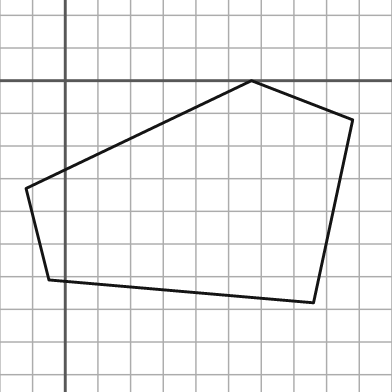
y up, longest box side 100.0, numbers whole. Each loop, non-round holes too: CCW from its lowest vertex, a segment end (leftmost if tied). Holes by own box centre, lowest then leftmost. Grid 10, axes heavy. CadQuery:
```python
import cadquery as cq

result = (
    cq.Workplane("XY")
    .moveTo(76.0, -68.0)
    .lineTo(88.0, -12.0)
    .lineTo(57.0, 0.0)
    .lineTo(-12.0, -33.0)
    .lineTo(-5.0, -61.0)
    .close()
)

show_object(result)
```